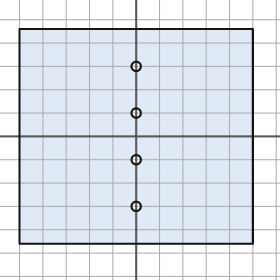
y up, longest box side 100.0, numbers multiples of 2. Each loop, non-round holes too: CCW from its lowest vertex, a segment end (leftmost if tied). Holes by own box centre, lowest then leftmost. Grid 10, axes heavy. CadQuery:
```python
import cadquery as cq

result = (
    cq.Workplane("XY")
    .moveTo(-50.0, -46.0)
    .lineTo(50.0, -46.0)
    .lineTo(50.0, 46.0)
    .lineTo(-50.0, 46.0)
    .close()
    .moveTo(0.0, -30.0)
    .circle(2.0)
    .moveTo(0.0, -10.0)
    .circle(2.0)
    .moveTo(0.0, 10.0)
    .circle(2.0)
    .moveTo(0.0, 30.0)
    .circle(2.0)
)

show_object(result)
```